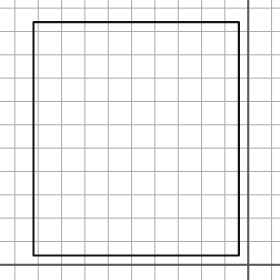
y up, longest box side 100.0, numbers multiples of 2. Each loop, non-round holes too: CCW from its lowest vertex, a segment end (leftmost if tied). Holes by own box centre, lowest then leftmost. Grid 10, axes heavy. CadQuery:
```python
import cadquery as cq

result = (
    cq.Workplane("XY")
    .moveTo(-92.0, 4.0)
    .lineTo(-4.0, 4.0)
    .lineTo(-4.0, 104.0)
    .lineTo(-92.0, 104.0)
    .close()
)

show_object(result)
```